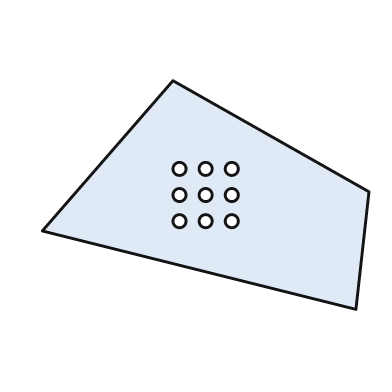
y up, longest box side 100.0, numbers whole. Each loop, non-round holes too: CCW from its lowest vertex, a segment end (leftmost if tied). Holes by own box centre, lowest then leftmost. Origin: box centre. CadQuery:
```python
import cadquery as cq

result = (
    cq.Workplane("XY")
    .moveTo(46.0, -35.0)
    .lineTo(50.0, 1.0)
    .lineTo(-10.0, 35.0)
    .lineTo(-50.0, -11.0)
    .close()
    .moveTo(-8.0, -8.0)
    .circle(2.0)
    .moveTo(0.0, -8.0)
    .circle(2.0)
    .moveTo(8.0, -8.0)
    .circle(2.0)
    .moveTo(-8.0, 0.0)
    .circle(2.0)
    .moveTo(0.0, 0.0)
    .circle(2.0)
    .moveTo(8.0, 0.0)
    .circle(2.0)
    .moveTo(-8.0, 8.0)
    .circle(2.0)
    .moveTo(0.0, 8.0)
    .circle(2.0)
    .moveTo(8.0, 8.0)
    .circle(2.0)
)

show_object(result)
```